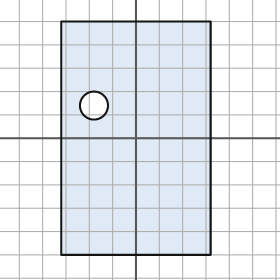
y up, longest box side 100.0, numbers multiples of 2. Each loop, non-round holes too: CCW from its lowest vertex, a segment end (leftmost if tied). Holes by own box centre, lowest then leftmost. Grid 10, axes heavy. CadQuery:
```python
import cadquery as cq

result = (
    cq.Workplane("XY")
    .moveTo(-32.0, -50.0)
    .lineTo(32.0, -50.0)
    .lineTo(32.0, 50.0)
    .lineTo(-32.0, 50.0)
    .close()
    .moveTo(-18.0, 14.0)
    .circle(6.0)
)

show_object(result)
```